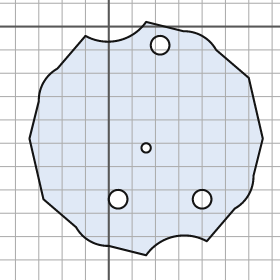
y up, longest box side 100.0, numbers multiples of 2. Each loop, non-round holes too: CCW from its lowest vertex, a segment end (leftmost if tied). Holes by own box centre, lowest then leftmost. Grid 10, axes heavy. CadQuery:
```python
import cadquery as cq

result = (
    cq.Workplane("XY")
    .moveTo(16.0, -98.0)
    .threePointArc((28.0, -90.0), (42.0, -92.0))
    .lineTo(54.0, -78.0)
    .threePointArc((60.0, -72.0), (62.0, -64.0))
    .lineTo(66.0, -48.0)
    .lineTo(60.0, -22.0)
    .lineTo(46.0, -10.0)
    .threePointArc((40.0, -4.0), (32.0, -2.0))
    .lineTo(16.0, 2.0)
    .threePointArc((4.0, -6.0), (-10.0, -4.0))
    .lineTo(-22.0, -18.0)
    .threePointArc((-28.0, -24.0), (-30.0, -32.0))
    .lineTo(-34.0, -48.0)
    .lineTo(-28.0, -74.0)
    .lineTo(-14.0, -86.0)
    .threePointArc((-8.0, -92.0), (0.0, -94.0))
    .close()
    .moveTo(4.0, -74.0)
    .circle(4.0)
    .moveTo(40.0, -74.0)
    .circle(4.0)
    .moveTo(16.0, -52.0)
    .circle(2.0)
    .moveTo(22.0, -8.0)
    .circle(4.0)
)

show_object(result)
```